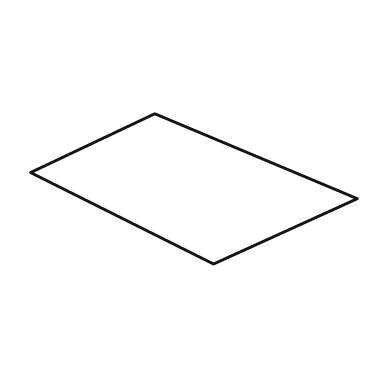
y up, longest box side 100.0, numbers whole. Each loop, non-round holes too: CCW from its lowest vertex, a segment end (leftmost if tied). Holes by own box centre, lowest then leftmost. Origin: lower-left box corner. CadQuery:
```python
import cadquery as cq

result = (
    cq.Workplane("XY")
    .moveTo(56.0, 0.0)
    .lineTo(100.0, 20.0)
    .lineTo(38.0, 46.0)
    .lineTo(0.0, 28.0)
    .close()
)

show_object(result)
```